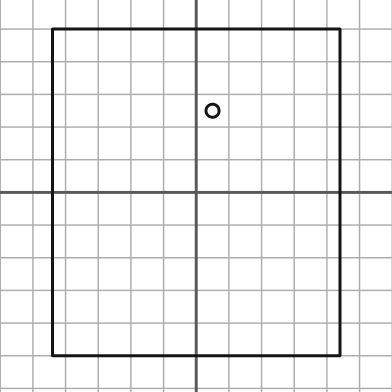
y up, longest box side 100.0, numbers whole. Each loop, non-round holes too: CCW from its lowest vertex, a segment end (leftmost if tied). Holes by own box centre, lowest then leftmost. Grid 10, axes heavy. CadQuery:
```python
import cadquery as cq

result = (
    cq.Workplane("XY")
    .moveTo(-44.0, -50.0)
    .lineTo(44.0, -50.0)
    .lineTo(44.0, 50.0)
    .lineTo(-44.0, 50.0)
    .close()
    .moveTo(5.0, 25.0)
    .circle(2.0)
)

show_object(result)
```